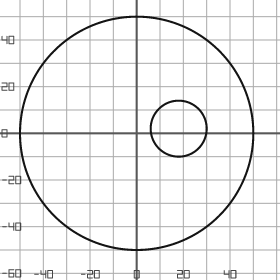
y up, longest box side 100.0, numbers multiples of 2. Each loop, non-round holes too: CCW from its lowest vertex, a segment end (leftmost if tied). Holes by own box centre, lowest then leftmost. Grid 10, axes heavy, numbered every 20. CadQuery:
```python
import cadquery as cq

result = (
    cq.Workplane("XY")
    .moveTo(0.0, 0.0)
    .circle(50.0)
    .moveTo(18.0, 2.0)
    .circle(12.0)
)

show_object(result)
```